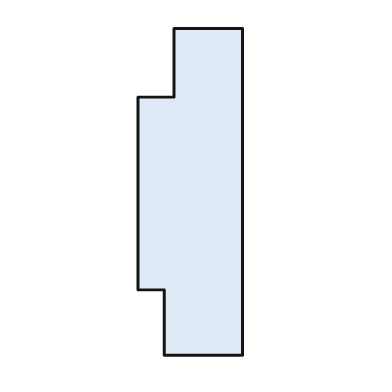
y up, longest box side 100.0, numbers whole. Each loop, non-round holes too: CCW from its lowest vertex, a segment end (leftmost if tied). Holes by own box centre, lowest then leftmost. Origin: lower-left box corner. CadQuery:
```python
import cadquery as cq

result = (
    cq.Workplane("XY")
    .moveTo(8.0, 0.0)
    .lineTo(32.0, 0.0)
    .lineTo(32.0, 100.0)
    .lineTo(11.0, 100.0)
    .lineTo(11.0, 79.0)
    .lineTo(0.0, 79.0)
    .lineTo(0.0, 20.0)
    .lineTo(8.0, 20.0)
    .close()
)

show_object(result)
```